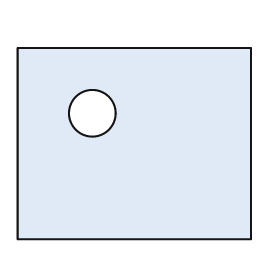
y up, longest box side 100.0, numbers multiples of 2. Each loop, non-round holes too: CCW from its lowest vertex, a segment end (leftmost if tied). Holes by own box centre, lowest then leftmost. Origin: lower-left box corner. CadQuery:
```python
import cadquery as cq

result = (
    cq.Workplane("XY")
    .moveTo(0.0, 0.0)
    .lineTo(100.0, 0.0)
    .lineTo(100.0, 82.0)
    .lineTo(0.0, 82.0)
    .close()
    .moveTo(32.0, 54.0)
    .circle(10.0)
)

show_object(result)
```